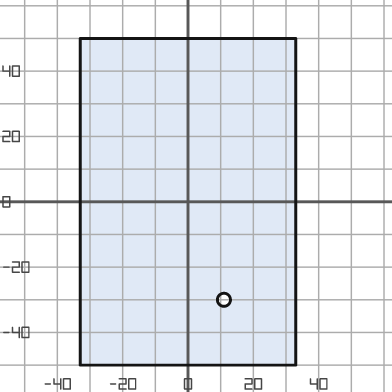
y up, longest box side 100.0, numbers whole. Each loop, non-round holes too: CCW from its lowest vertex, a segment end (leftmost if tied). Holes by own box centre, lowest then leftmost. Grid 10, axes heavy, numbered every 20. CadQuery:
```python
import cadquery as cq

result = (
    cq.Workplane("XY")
    .moveTo(-33.0, -50.0)
    .lineTo(33.0, -50.0)
    .lineTo(33.0, 50.0)
    .lineTo(-33.0, 50.0)
    .close()
    .moveTo(11.0, -30.0)
    .circle(2.0)
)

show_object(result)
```